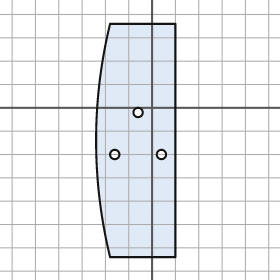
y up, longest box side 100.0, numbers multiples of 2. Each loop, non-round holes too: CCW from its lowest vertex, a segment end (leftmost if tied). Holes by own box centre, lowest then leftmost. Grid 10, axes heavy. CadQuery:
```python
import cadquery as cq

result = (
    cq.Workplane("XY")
    .moveTo(-18.0, -64.0)
    .lineTo(10.0, -64.0)
    .lineTo(10.0, 36.0)
    .lineTo(-18.0, 36.0)
    .threePointArc((-24.0, -14.0), (-18.0, -64.0))
    .close()
    .moveTo(-16.0, -20.0)
    .circle(2.0)
    .moveTo(4.0, -20.0)
    .circle(2.0)
    .moveTo(-6.0, -2.0)
    .circle(2.0)
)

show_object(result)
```